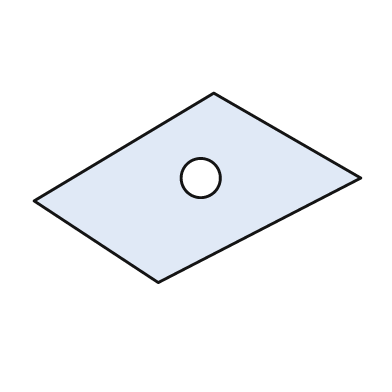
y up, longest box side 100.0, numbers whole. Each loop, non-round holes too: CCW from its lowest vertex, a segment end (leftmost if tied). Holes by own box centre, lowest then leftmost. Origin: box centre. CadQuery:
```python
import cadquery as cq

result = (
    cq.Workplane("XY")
    .moveTo(-12.0, -29.0)
    .lineTo(50.0, 3.0)
    .lineTo(5.0, 29.0)
    .lineTo(-50.0, -4.0)
    .close()
    .moveTo(1.0, 3.0)
    .circle(6.0)
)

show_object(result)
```